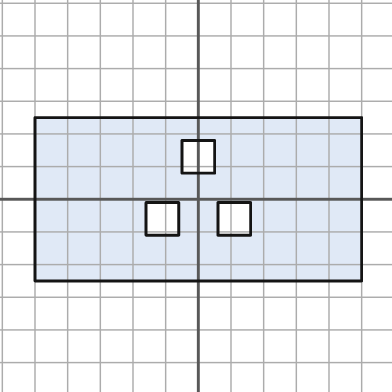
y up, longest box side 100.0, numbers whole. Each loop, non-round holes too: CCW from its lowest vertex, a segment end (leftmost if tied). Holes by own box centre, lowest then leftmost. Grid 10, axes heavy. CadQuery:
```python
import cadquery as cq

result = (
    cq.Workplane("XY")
    .moveTo(-50.0, -25.0)
    .lineTo(50.0, -25.0)
    .lineTo(50.0, 25.0)
    .lineTo(-50.0, 25.0)
    .close()
    .moveTo(-16.0, -11.0)
    .lineTo(-6.0, -11.0)
    .lineTo(-6.0, -1.0)
    .lineTo(-16.0, -1.0)
    .close()
    .moveTo(6.0, -11.0)
    .lineTo(16.0, -11.0)
    .lineTo(16.0, -1.0)
    .lineTo(6.0, -1.0)
    .close()
    .moveTo(-5.0, 8.0)
    .lineTo(5.0, 8.0)
    .lineTo(5.0, 18.0)
    .lineTo(-5.0, 18.0)
    .close()
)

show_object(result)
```